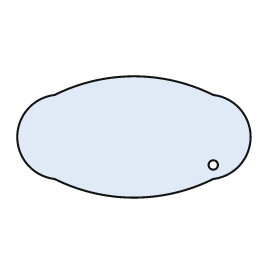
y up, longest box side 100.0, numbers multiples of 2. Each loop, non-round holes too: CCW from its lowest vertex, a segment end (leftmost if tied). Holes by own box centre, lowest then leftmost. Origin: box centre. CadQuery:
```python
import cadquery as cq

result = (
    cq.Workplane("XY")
    .moveTo(-34.0, -18.0)
    .threePointArc((0.0, -26.0), (34.0, -18.0))
    .threePointArc((50.0, 0.0), (34.0, 18.0))
    .threePointArc((0.0, 26.0), (-34.0, 18.0))
    .threePointArc((-50.0, 0.0), (-34.0, -18.0))
    .close()
    .moveTo(34.0, -12.0)
    .circle(2.0)
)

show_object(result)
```